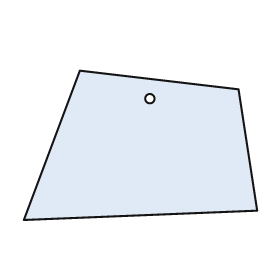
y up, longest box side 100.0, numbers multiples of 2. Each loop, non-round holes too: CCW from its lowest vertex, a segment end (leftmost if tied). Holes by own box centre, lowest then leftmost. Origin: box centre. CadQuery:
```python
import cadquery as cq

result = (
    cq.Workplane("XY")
    .moveTo(-50.0, -32.0)
    .lineTo(50.0, -28.0)
    .lineTo(42.0, 24.0)
    .lineTo(-26.0, 32.0)
    .close()
    .moveTo(4.0, 20.0)
    .circle(2.0)
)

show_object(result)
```